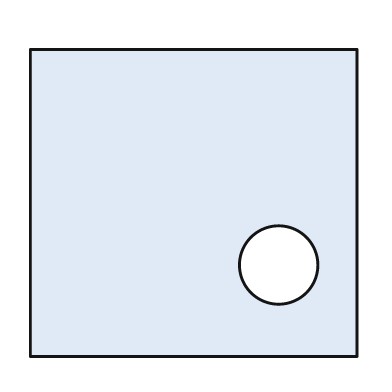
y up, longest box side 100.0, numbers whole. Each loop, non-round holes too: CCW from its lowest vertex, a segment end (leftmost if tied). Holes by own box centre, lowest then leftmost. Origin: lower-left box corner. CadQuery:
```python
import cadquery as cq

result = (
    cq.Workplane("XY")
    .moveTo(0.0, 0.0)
    .lineTo(100.0, 0.0)
    .lineTo(100.0, 94.0)
    .lineTo(0.0, 94.0)
    .close()
    .moveTo(76.0, 28.0)
    .circle(12.0)
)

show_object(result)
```